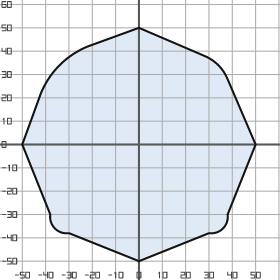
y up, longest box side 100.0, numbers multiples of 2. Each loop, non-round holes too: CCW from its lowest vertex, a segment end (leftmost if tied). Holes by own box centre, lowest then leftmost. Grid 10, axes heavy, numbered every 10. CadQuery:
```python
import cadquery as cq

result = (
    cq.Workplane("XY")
    .moveTo(0.0, -50.0)
    .lineTo(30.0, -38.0)
    .threePointArc((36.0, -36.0), (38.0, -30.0))
    .lineTo(50.0, 0.0)
    .lineTo(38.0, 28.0)
    .threePointArc((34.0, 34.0), (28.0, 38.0))
    .lineTo(0.0, 50.0)
    .lineTo(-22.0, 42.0)
    .threePointArc((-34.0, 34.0), (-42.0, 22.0))
    .lineTo(-50.0, 0.0)
    .lineTo(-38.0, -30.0)
    .threePointArc((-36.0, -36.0), (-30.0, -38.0))
    .close()
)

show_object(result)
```